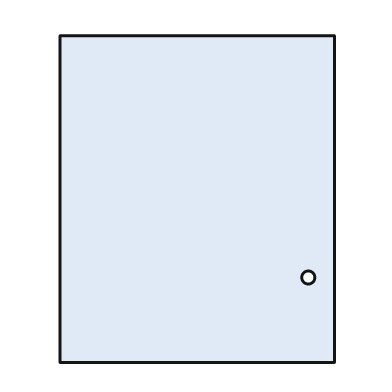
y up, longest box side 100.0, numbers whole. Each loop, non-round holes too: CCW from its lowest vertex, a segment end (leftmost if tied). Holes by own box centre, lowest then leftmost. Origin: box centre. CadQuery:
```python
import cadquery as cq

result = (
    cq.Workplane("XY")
    .moveTo(-42.0, -50.0)
    .lineTo(42.0, -50.0)
    .lineTo(42.0, 50.0)
    .lineTo(-42.0, 50.0)
    .close()
    .moveTo(34.0, -24.0)
    .circle(2.0)
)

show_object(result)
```